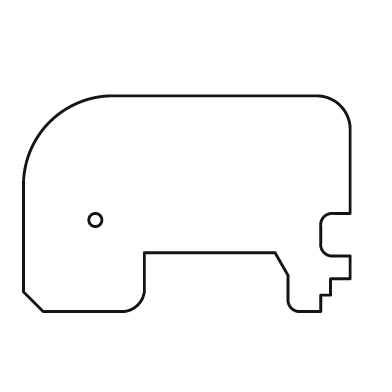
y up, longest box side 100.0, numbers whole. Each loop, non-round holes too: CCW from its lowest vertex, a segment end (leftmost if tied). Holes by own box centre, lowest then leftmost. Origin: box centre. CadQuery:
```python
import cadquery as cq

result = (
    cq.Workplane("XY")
    .moveTo(-44.0, -33.0)
    .lineTo(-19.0, -33.0)
    .threePointArc((-15.0, -31.0), (-13.0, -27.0))
    .lineTo(-13.0, -15.0)
    .lineTo(27.0, -15.0)
    .lineTo(31.0, -22.0)
    .lineTo(31.0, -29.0)
    .threePointArc((32.0, -32.0), (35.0, -33.0))
    .lineTo(41.0, -33.0)
    .lineTo(41.0, -28.0)
    .lineTo(44.0, -28.0)
    .lineTo(44.0, -23.0)
    .lineTo(50.0, -23.0)
    .lineTo(50.0, -16.0)
    .lineTo(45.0, -16.0)
    .threePointArc((42.0, -15.0), (41.0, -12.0))
    .lineTo(41.0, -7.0)
    .threePointArc((42.0, -4.0), (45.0, -3.0))
    .lineTo(50.0, -3.0)
    .lineTo(50.0, 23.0)
    .threePointArc((47.0, 30.0), (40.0, 33.0))
    .lineTo(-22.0, 33.0)
    .threePointArc((-42.0, 25.0), (-50.0, 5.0))
    .lineTo(-50.0, -27.0)
    .close()
    .moveTo(-28.0, -5.0)
    .circle(2.0)
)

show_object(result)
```